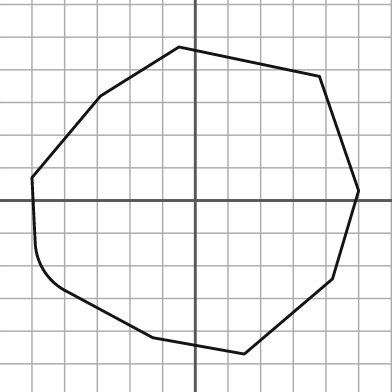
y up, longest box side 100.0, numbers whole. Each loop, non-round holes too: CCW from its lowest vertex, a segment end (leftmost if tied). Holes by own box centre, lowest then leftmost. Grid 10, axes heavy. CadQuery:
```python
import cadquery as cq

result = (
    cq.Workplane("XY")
    .moveTo(15.0, -47.0)
    .lineTo(42.0, -24.0)
    .lineTo(50.0, 3.0)
    .lineTo(38.0, 38.0)
    .lineTo(-5.0, 47.0)
    .lineTo(-29.0, 32.0)
    .lineTo(-50.0, 7.0)
    .lineTo(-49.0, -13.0)
    .threePointArc((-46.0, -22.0), (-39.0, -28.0))
    .lineTo(-13.0, -42.0)
    .close()
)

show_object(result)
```